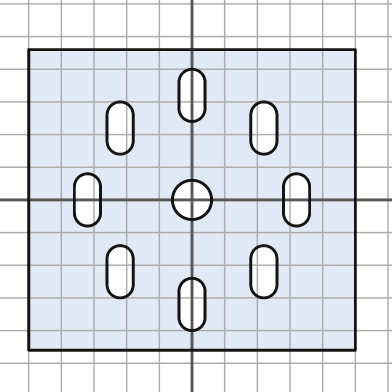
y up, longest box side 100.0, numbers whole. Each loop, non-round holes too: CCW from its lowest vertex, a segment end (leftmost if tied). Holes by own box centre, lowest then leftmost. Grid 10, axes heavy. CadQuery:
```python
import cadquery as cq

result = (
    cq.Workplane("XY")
    .moveTo(-50.0, -46.0)
    .lineTo(50.0, -46.0)
    .lineTo(50.0, 46.0)
    .lineTo(-50.0, 46.0)
    .close()
    .moveTo(-4.0, -36.0)
    .threePointArc((0.0, -40.0), (4.0, -36.0))
    .lineTo(4.0, -28.0)
    .threePointArc((0.0, -24.0), (-4.0, -28.0))
    .close()
    .moveTo(-26.0, -26.0)
    .threePointArc((-22.0, -30.0), (-18.0, -26.0))
    .lineTo(-18.0, -18.0)
    .threePointArc((-22.0, -14.0), (-26.0, -18.0))
    .close()
    .moveTo(18.0, -26.0)
    .threePointArc((22.0, -30.0), (26.0, -26.0))
    .lineTo(26.0, -18.0)
    .threePointArc((22.0, -14.0), (18.0, -18.0))
    .close()
    .moveTo(-36.0, -4.0)
    .threePointArc((-32.0, -8.0), (-28.0, -4.0))
    .lineTo(-28.0, 4.0)
    .threePointArc((-32.0, 8.0), (-36.0, 4.0))
    .close()
    .moveTo(0.0, 0.0)
    .circle(6.0)
    .moveTo(28.0, -4.0)
    .threePointArc((32.0, -8.0), (36.0, -4.0))
    .lineTo(36.0, 4.0)
    .threePointArc((32.0, 8.0), (28.0, 4.0))
    .close()
    .moveTo(-26.0, 18.0)
    .threePointArc((-22.0, 14.0), (-18.0, 18.0))
    .lineTo(-18.0, 26.0)
    .threePointArc((-22.0, 30.0), (-26.0, 26.0))
    .close()
    .moveTo(18.0, 18.0)
    .threePointArc((22.0, 14.0), (26.0, 18.0))
    .lineTo(26.0, 26.0)
    .threePointArc((22.0, 30.0), (18.0, 26.0))
    .close()
    .moveTo(-4.0, 28.0)
    .threePointArc((0.0, 24.0), (4.0, 28.0))
    .lineTo(4.0, 36.0)
    .threePointArc((0.0, 40.0), (-4.0, 36.0))
    .close()
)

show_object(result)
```